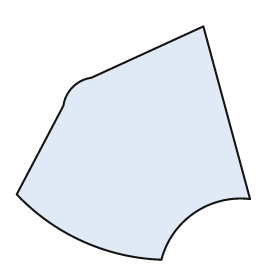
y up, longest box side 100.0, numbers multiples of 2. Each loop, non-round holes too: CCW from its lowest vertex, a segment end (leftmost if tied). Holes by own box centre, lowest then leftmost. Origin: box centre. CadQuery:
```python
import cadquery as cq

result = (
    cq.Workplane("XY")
    .moveTo(12.0, -50.0)
    .threePointArc((26.0, -30.0), (50.0, -24.0))
    .lineTo(30.0, 50.0)
    .lineTo(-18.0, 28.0)
    .threePointArc((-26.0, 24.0), (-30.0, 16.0))
    .lineTo(-50.0, -22.0)
    .threePointArc((-22.0, -42.0), (12.0, -50.0))
    .close()
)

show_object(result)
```